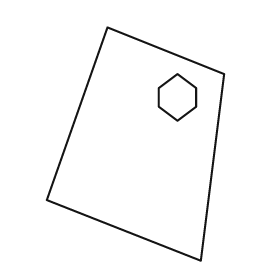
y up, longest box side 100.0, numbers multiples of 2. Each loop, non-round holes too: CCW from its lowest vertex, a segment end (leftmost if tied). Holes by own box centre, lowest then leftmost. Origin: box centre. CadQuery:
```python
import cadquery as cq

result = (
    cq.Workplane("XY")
    .moveTo(28.0, -50.0)
    .lineTo(38.0, 30.0)
    .lineTo(-12.0, 50.0)
    .lineTo(-38.0, -24.0)
    .close()
    .moveTo(18.0, 10.0)
    .lineTo(26.0, 16.0)
    .lineTo(26.0, 24.0)
    .lineTo(18.0, 30.0)
    .lineTo(10.0, 24.0)
    .lineTo(10.0, 16.0)
    .close()
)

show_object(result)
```